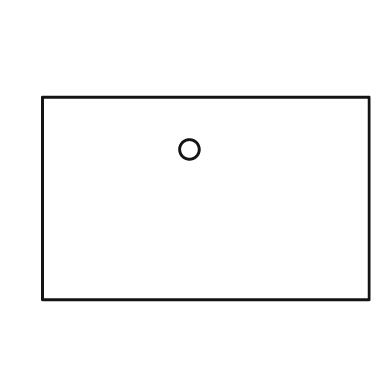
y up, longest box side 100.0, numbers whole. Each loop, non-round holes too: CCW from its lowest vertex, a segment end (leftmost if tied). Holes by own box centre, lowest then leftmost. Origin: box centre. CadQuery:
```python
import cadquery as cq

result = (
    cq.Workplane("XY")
    .moveTo(-50.0, -31.0)
    .lineTo(50.0, -31.0)
    .lineTo(50.0, 31.0)
    .lineTo(-50.0, 31.0)
    .close()
    .moveTo(-5.0, 15.0)
    .circle(3.0)
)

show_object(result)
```